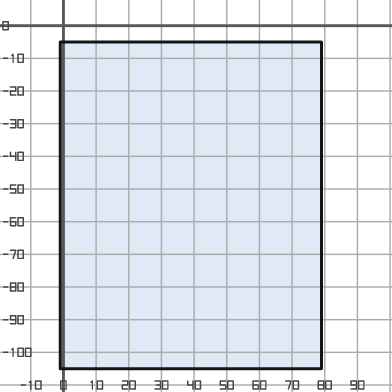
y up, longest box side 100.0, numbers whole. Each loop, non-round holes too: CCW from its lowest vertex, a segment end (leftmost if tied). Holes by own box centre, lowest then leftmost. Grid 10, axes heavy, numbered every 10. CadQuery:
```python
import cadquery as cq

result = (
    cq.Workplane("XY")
    .moveTo(-1.0, -105.0)
    .lineTo(79.0, -105.0)
    .lineTo(79.0, -5.0)
    .lineTo(-1.0, -5.0)
    .close()
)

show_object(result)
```